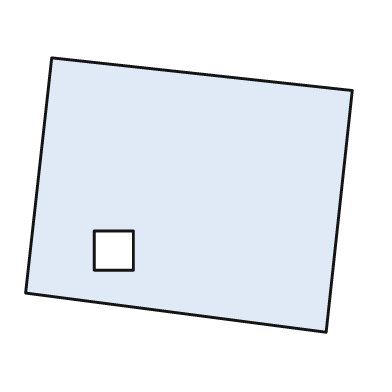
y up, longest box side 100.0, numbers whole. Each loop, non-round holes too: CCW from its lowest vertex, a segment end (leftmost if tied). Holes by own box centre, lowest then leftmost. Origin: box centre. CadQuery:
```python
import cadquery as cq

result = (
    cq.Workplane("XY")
    .moveTo(42.0, -42.0)
    .lineTo(50.0, 32.0)
    .lineTo(-42.0, 42.0)
    .lineTo(-50.0, -30.0)
    .close()
    .moveTo(-29.0, -23.0)
    .lineTo(-17.0, -23.0)
    .lineTo(-17.0, -11.0)
    .lineTo(-29.0, -11.0)
    .close()
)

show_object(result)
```